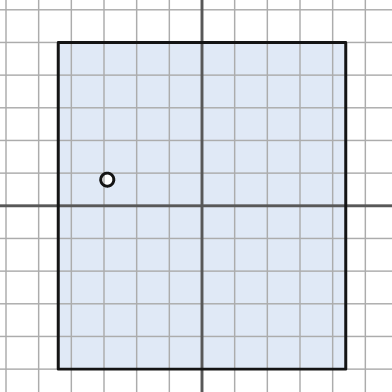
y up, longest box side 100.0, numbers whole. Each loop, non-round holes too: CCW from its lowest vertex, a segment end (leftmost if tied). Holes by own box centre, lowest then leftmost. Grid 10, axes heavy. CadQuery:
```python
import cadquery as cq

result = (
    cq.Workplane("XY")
    .moveTo(-44.0, -50.0)
    .lineTo(44.0, -50.0)
    .lineTo(44.0, 50.0)
    .lineTo(-44.0, 50.0)
    .close()
    .moveTo(-29.0, 8.0)
    .circle(2.0)
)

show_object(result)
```